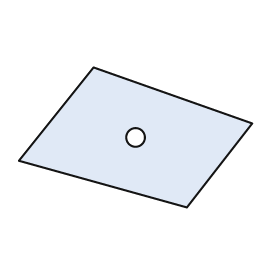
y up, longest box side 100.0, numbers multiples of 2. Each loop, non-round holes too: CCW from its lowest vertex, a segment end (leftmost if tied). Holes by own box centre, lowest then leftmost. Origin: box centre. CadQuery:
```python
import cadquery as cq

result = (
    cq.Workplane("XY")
    .moveTo(22.0, -30.0)
    .lineTo(50.0, 6.0)
    .lineTo(-18.0, 30.0)
    .lineTo(-50.0, -10.0)
    .close()
    .moveTo(0.0, 0.0)
    .circle(4.0)
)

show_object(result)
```